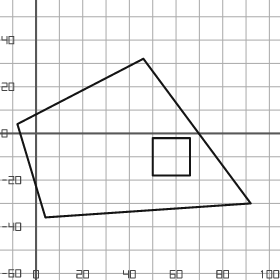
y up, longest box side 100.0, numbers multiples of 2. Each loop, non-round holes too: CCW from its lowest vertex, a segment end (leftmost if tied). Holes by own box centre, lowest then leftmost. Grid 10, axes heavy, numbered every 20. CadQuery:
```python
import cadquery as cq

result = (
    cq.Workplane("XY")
    .moveTo(4.0, -36.0)
    .lineTo(92.0, -30.0)
    .lineTo(46.0, 32.0)
    .lineTo(-8.0, 4.0)
    .close()
    .moveTo(50.0, -18.0)
    .lineTo(66.0, -18.0)
    .lineTo(66.0, -2.0)
    .lineTo(50.0, -2.0)
    .close()
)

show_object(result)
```